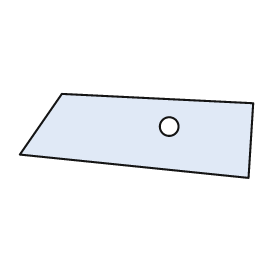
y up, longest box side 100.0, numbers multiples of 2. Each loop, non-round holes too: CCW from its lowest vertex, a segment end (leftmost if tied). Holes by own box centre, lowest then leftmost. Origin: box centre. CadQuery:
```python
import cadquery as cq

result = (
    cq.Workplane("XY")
    .moveTo(48.0, -18.0)
    .lineTo(50.0, 14.0)
    .lineTo(-32.0, 18.0)
    .lineTo(-50.0, -8.0)
    .close()
    .moveTo(14.0, 4.0)
    .circle(4.0)
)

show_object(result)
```